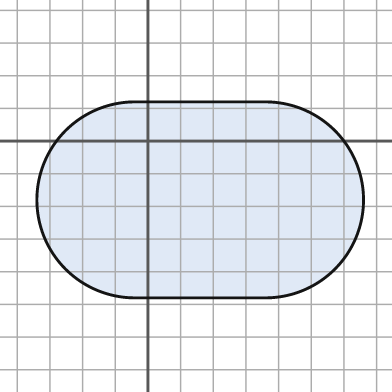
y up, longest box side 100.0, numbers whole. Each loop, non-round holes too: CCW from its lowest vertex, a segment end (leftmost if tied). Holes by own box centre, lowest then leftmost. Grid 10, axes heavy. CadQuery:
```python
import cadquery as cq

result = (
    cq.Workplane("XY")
    .moveTo(-4.0, -48.0)
    .lineTo(36.0, -48.0)
    .threePointArc((66.0, -18.0), (36.0, 12.0))
    .lineTo(-4.0, 12.0)
    .threePointArc((-34.0, -18.0), (-4.0, -48.0))
    .close()
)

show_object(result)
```